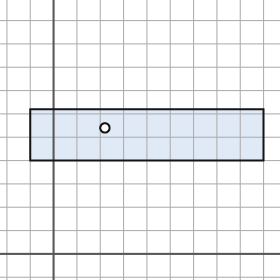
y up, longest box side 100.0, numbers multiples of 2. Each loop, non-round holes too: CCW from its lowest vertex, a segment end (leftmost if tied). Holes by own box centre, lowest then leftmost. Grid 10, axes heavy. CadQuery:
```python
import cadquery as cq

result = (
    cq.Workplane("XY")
    .moveTo(-10.0, 40.0)
    .lineTo(90.0, 40.0)
    .lineTo(90.0, 62.0)
    .lineTo(-10.0, 62.0)
    .close()
    .moveTo(22.0, 54.0)
    .circle(2.0)
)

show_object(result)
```